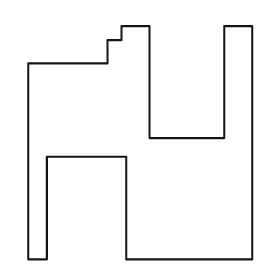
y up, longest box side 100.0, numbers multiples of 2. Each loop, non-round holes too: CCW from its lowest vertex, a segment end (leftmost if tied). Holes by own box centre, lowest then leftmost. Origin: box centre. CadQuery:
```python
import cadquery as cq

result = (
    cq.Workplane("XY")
    .moveTo(-48.0, -50.0)
    .lineTo(-40.0, -50.0)
    .lineTo(-40.0, -6.0)
    .lineTo(-6.0, -6.0)
    .lineTo(-6.0, -50.0)
    .lineTo(48.0, -50.0)
    .lineTo(48.0, 50.0)
    .lineTo(36.0, 50.0)
    .lineTo(36.0, 2.0)
    .lineTo(4.0, 2.0)
    .lineTo(4.0, 50.0)
    .lineTo(-8.0, 50.0)
    .lineTo(-8.0, 44.0)
    .lineTo(-14.0, 44.0)
    .lineTo(-14.0, 34.0)
    .lineTo(-48.0, 34.0)
    .close()
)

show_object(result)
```